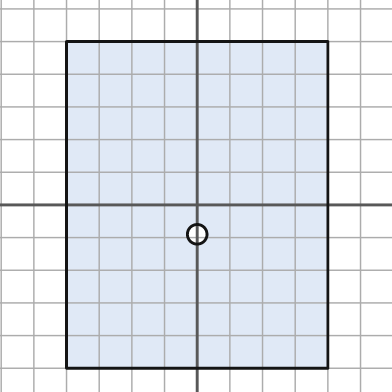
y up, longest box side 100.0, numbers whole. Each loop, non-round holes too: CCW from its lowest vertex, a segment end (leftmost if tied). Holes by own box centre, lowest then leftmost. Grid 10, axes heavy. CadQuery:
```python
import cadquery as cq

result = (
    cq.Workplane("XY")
    .moveTo(-40.0, -50.0)
    .lineTo(40.0, -50.0)
    .lineTo(40.0, 50.0)
    .lineTo(-40.0, 50.0)
    .close()
    .moveTo(0.0, -9.0)
    .circle(3.0)
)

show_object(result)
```